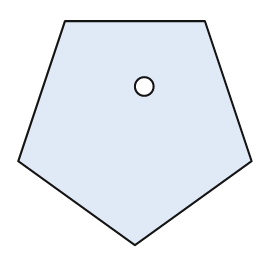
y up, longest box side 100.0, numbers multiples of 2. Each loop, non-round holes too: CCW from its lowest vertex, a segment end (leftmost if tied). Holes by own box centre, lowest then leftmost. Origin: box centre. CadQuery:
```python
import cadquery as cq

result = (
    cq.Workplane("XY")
    .moveTo(0.0, -48.0)
    .lineTo(50.0, -12.0)
    .lineTo(30.0, 48.0)
    .lineTo(-30.0, 48.0)
    .lineTo(-50.0, -12.0)
    .close()
    .moveTo(4.0, 20.0)
    .circle(4.0)
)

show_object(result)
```